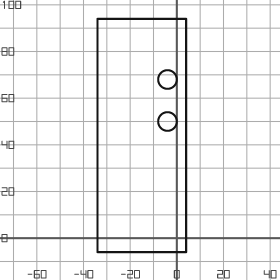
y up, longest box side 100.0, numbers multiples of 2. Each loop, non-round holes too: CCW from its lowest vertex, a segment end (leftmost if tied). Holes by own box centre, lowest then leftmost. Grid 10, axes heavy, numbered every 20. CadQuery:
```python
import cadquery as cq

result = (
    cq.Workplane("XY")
    .moveTo(-34.0, -6.0)
    .lineTo(4.0, -6.0)
    .lineTo(4.0, 94.0)
    .lineTo(-34.0, 94.0)
    .close()
    .moveTo(-4.0, 50.0)
    .circle(4.0)
    .moveTo(-4.0, 68.0)
    .circle(4.0)
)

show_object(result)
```